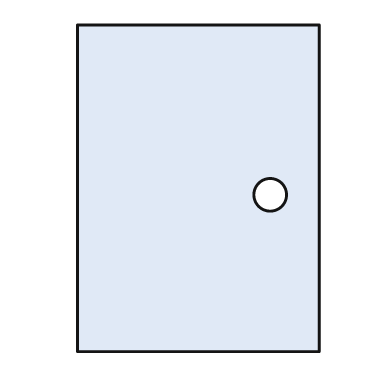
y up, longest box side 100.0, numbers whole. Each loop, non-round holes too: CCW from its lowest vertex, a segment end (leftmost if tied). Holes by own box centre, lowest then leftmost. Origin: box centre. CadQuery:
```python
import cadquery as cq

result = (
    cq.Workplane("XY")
    .moveTo(-37.0, -50.0)
    .lineTo(37.0, -50.0)
    .lineTo(37.0, 50.0)
    .lineTo(-37.0, 50.0)
    .close()
    .moveTo(22.0, -2.0)
    .circle(5.0)
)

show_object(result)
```